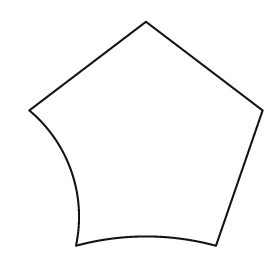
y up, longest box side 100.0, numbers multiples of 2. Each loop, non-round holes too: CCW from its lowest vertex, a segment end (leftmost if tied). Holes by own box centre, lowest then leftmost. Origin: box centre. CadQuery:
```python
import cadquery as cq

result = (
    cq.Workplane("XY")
    .moveTo(-30.0, -48.0)
    .threePointArc((0.0, -44.0), (30.0, -48.0))
    .lineTo(50.0, 10.0)
    .lineTo(0.0, 48.0)
    .lineTo(-50.0, 10.0)
    .threePointArc((-32.0, -16.0), (-30.0, -48.0))
    .close()
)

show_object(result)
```